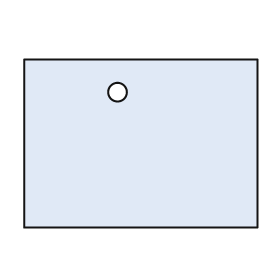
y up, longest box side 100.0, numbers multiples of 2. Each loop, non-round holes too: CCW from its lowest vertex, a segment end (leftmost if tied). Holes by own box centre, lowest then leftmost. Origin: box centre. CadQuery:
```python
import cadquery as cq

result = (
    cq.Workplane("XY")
    .moveTo(-50.0, -36.0)
    .lineTo(50.0, -36.0)
    .lineTo(50.0, 36.0)
    .lineTo(-50.0, 36.0)
    .close()
    .moveTo(-10.0, 22.0)
    .circle(4.0)
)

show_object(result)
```